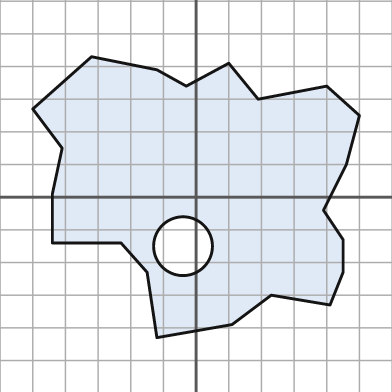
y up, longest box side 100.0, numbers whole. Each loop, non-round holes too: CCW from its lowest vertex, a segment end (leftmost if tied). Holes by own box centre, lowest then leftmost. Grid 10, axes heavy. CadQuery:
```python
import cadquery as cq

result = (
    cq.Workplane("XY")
    .moveTo(-12.0, -43.0)
    .lineTo(11.0, -39.0)
    .lineTo(23.0, -30.0)
    .lineTo(41.0, -33.0)
    .lineTo(45.0, -23.0)
    .lineTo(45.0, -13.0)
    .lineTo(39.0, -4.0)
    .lineTo(46.0, 10.0)
    .lineTo(50.0, 25.0)
    .lineTo(40.0, 34.0)
    .lineTo(19.0, 30.0)
    .lineTo(10.0, 41.0)
    .lineTo(-3.0, 34.0)
    .lineTo(-12.0, 39.0)
    .lineTo(-32.0, 43.0)
    .lineTo(-50.0, 27.0)
    .lineTo(-41.0, 15.0)
    .lineTo(-44.0, 1.0)
    .lineTo(-44.0, -14.0)
    .lineTo(-23.0, -14.0)
    .lineTo(-15.0, -23.0)
    .close()
    .moveTo(-4.0, -15.0)
    .circle(9.0)
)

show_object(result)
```